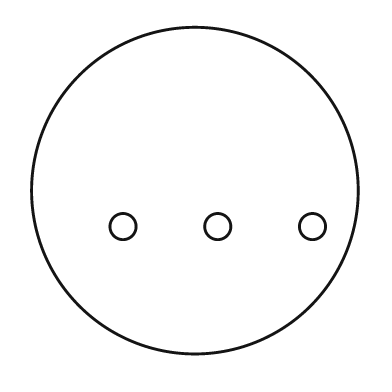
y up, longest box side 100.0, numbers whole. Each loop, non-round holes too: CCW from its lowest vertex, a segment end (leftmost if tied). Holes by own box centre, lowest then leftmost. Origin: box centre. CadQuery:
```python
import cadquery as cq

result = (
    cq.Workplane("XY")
    .moveTo(0.0, 0.0)
    .circle(50.0)
    .moveTo(-22.0, -11.0)
    .circle(4.0)
    .moveTo(7.0, -11.0)
    .circle(4.0)
    .moveTo(36.0, -11.0)
    .circle(4.0)
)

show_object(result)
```